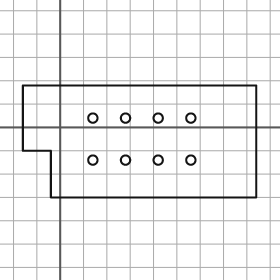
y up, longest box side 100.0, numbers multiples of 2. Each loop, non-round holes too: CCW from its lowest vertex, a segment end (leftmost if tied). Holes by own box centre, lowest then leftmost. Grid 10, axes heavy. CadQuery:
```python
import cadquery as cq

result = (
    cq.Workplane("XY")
    .moveTo(-4.0, -30.0)
    .lineTo(84.0, -30.0)
    .lineTo(84.0, 18.0)
    .lineTo(-16.0, 18.0)
    .lineTo(-16.0, -10.0)
    .lineTo(-4.0, -10.0)
    .close()
    .moveTo(14.0, -14.0)
    .circle(2.0)
    .moveTo(28.0, -14.0)
    .circle(2.0)
    .moveTo(42.0, -14.0)
    .circle(2.0)
    .moveTo(56.0, -14.0)
    .circle(2.0)
    .moveTo(14.0, 4.0)
    .circle(2.0)
    .moveTo(28.0, 4.0)
    .circle(2.0)
    .moveTo(42.0, 4.0)
    .circle(2.0)
    .moveTo(56.0, 4.0)
    .circle(2.0)
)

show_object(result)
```